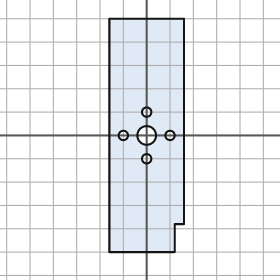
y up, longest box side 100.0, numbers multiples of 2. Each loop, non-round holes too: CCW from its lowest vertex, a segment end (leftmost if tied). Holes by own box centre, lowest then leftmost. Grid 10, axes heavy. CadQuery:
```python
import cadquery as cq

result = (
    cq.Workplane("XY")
    .moveTo(-16.0, -50.0)
    .lineTo(12.0, -50.0)
    .lineTo(12.0, -38.0)
    .lineTo(16.0, -38.0)
    .lineTo(16.0, 50.0)
    .lineTo(-16.0, 50.0)
    .close()
    .moveTo(0.0, -10.0)
    .circle(2.0)
    .moveTo(-10.0, 0.0)
    .circle(2.0)
    .moveTo(0.0, 0.0)
    .circle(4.0)
    .moveTo(10.0, 0.0)
    .circle(2.0)
    .moveTo(0.0, 10.0)
    .circle(2.0)
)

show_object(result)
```